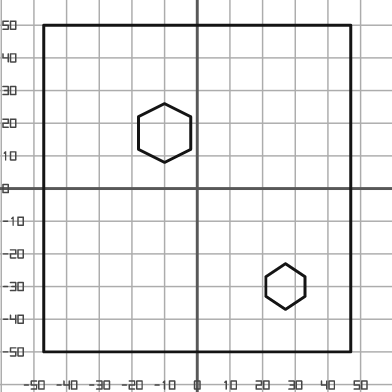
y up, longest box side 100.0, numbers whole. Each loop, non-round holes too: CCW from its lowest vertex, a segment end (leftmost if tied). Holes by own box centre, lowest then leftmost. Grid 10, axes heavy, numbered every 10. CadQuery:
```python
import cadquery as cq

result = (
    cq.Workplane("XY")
    .moveTo(-47.0, -50.0)
    .lineTo(47.0, -50.0)
    .lineTo(47.0, 50.0)
    .lineTo(-47.0, 50.0)
    .close()
    .moveTo(27.0, -37.0)
    .lineTo(33.0, -33.0)
    .lineTo(33.0, -27.0)
    .lineTo(27.0, -23.0)
    .lineTo(21.0, -27.0)
    .lineTo(21.0, -33.0)
    .close()
    .moveTo(-10.0, 8.0)
    .lineTo(-2.0, 12.0)
    .lineTo(-2.0, 22.0)
    .lineTo(-10.0, 26.0)
    .lineTo(-18.0, 22.0)
    .lineTo(-18.0, 12.0)
    .close()
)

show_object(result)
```